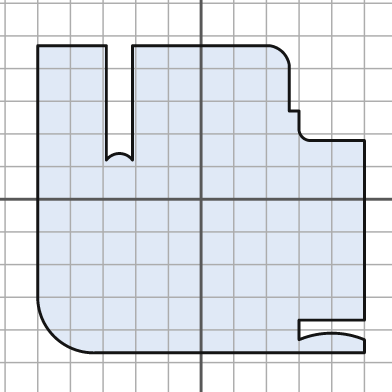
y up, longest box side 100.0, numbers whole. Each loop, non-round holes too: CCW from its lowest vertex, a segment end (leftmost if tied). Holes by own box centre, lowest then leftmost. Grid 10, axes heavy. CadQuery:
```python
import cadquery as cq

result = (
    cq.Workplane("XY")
    .moveTo(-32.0, -47.0)
    .lineTo(50.0, -47.0)
    .lineTo(50.0, -43.0)
    .threePointArc((40.0, -41.0), (30.0, -43.0))
    .lineTo(30.0, -37.0)
    .lineTo(50.0, -37.0)
    .lineTo(50.0, 18.0)
    .lineTo(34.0, 18.0)
    .threePointArc((31.0, 19.0), (30.0, 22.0))
    .lineTo(30.0, 27.0)
    .lineTo(27.0, 27.0)
    .lineTo(27.0, 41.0)
    .threePointArc((25.0, 45.0), (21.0, 47.0))
    .lineTo(-21.0, 47.0)
    .lineTo(-21.0, 12.0)
    .threePointArc((-25.0, 14.0), (-29.0, 12.0))
    .lineTo(-29.0, 47.0)
    .lineTo(-50.0, 47.0)
    .lineTo(-50.0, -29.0)
    .threePointArc((-45.0, -42.0), (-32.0, -47.0))
    .close()
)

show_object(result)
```